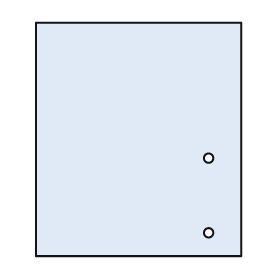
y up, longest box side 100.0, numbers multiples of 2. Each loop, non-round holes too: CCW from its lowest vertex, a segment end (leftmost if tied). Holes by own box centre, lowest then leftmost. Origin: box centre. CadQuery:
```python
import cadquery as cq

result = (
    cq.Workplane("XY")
    .moveTo(-44.0, -50.0)
    .lineTo(44.0, -50.0)
    .lineTo(44.0, 50.0)
    .lineTo(-44.0, 50.0)
    .close()
    .moveTo(30.0, -40.0)
    .circle(2.0)
    .moveTo(30.0, -8.0)
    .circle(2.0)
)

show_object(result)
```